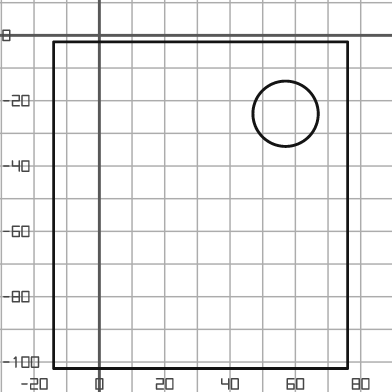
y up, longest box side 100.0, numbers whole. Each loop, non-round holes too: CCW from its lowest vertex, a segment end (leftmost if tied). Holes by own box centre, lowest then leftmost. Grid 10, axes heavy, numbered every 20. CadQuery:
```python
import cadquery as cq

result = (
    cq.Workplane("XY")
    .moveTo(-14.0, -102.0)
    .lineTo(76.0, -102.0)
    .lineTo(76.0, -2.0)
    .lineTo(-14.0, -2.0)
    .close()
    .moveTo(57.0, -24.0)
    .circle(10.0)
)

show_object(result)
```